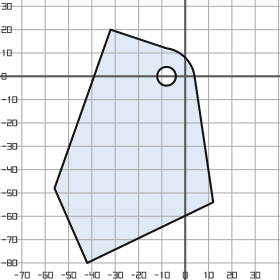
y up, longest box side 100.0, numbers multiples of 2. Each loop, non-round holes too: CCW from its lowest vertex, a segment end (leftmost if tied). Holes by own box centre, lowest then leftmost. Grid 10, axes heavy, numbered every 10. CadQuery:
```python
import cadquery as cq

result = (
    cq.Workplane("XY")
    .moveTo(-42.0, -80.0)
    .lineTo(12.0, -54.0)
    .lineTo(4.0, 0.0)
    .threePointArc((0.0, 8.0), (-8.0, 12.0))
    .lineTo(-32.0, 20.0)
    .lineTo(-56.0, -48.0)
    .close()
    .moveTo(-8.0, 0.0)
    .circle(4.0)
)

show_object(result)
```